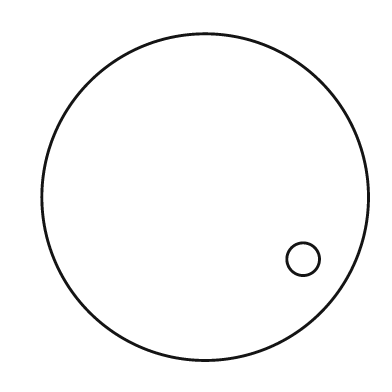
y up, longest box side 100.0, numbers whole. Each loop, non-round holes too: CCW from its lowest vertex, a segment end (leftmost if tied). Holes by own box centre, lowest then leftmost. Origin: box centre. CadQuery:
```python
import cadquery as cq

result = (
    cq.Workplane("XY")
    .moveTo(0.0, 0.0)
    .circle(50.0)
    .moveTo(30.0, -19.0)
    .circle(5.0)
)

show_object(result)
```